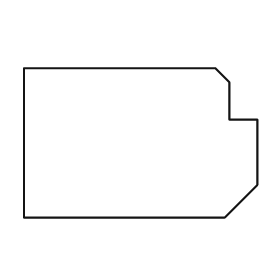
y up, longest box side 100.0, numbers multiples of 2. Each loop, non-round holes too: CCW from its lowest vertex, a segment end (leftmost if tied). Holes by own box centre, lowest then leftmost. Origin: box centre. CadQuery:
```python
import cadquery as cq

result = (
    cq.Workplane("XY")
    .moveTo(-50.0, -32.0)
    .lineTo(36.0, -32.0)
    .lineTo(50.0, -18.0)
    .lineTo(50.0, 10.0)
    .lineTo(38.0, 10.0)
    .lineTo(38.0, 26.0)
    .lineTo(32.0, 32.0)
    .lineTo(-50.0, 32.0)
    .close()
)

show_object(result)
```